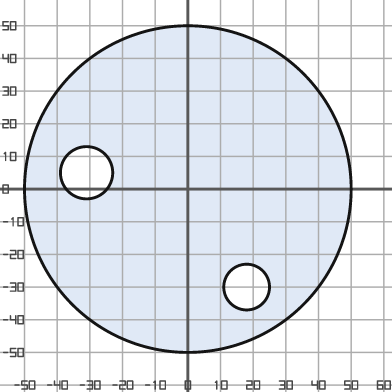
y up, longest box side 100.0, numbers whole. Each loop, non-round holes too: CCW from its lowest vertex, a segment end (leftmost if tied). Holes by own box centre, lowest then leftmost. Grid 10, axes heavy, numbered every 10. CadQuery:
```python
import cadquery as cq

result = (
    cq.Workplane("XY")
    .moveTo(0.0, 0.0)
    .circle(50.0)
    .moveTo(18.0, -30.0)
    .circle(7.0)
    .moveTo(-31.0, 5.0)
    .circle(8.0)
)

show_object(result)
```